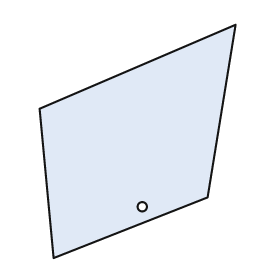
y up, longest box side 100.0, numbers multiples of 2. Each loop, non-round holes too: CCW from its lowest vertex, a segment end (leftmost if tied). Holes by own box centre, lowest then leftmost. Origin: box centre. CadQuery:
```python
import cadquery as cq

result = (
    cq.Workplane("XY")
    .moveTo(-36.0, -50.0)
    .lineTo(30.0, -24.0)
    .lineTo(42.0, 50.0)
    .lineTo(-42.0, 14.0)
    .close()
    .moveTo(2.0, -28.0)
    .circle(2.0)
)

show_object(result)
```